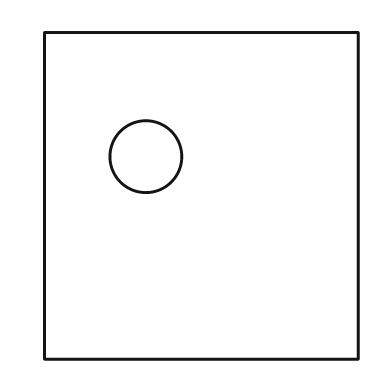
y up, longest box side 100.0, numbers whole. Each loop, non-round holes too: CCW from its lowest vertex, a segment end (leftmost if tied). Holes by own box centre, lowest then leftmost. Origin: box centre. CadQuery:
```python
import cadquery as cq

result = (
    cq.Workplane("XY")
    .moveTo(-48.0, -50.0)
    .lineTo(48.0, -50.0)
    .lineTo(48.0, 50.0)
    .lineTo(-48.0, 50.0)
    .close()
    .moveTo(-17.0, 12.0)
    .circle(11.0)
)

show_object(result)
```